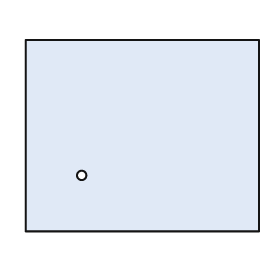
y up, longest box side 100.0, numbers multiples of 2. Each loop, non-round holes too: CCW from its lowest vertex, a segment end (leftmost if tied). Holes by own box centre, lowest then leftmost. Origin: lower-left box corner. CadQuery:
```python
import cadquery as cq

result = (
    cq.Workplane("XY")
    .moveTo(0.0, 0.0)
    .lineTo(100.0, 0.0)
    .lineTo(100.0, 82.0)
    .lineTo(0.0, 82.0)
    .close()
    .moveTo(24.0, 24.0)
    .circle(2.0)
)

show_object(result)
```